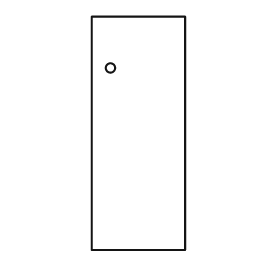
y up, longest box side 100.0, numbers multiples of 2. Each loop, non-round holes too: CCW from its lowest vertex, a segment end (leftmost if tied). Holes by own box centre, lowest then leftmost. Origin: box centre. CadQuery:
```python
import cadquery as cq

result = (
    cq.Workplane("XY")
    .moveTo(-20.0, -50.0)
    .lineTo(20.0, -50.0)
    .lineTo(20.0, 50.0)
    .lineTo(-20.0, 50.0)
    .close()
    .moveTo(-12.0, 28.0)
    .circle(2.0)
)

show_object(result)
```